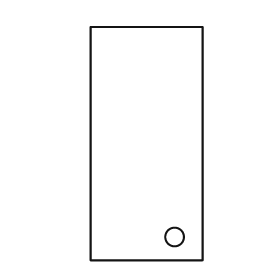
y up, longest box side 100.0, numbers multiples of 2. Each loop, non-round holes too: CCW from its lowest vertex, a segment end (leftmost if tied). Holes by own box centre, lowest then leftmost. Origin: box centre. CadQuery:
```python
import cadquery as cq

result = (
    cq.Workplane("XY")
    .moveTo(-24.0, -50.0)
    .lineTo(24.0, -50.0)
    .lineTo(24.0, 50.0)
    .lineTo(-24.0, 50.0)
    .close()
    .moveTo(12.0, -40.0)
    .circle(4.0)
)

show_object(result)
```